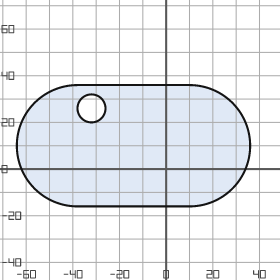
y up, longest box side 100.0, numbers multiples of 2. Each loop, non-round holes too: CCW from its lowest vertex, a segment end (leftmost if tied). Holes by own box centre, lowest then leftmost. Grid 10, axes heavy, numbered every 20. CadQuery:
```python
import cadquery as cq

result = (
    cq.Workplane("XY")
    .moveTo(-38.0, -16.0)
    .lineTo(10.0, -16.0)
    .threePointArc((36.0, 10.0), (10.0, 36.0))
    .lineTo(-38.0, 36.0)
    .threePointArc((-64.0, 10.0), (-38.0, -16.0))
    .close()
    .moveTo(-32.0, 26.0)
    .circle(6.0)
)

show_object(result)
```